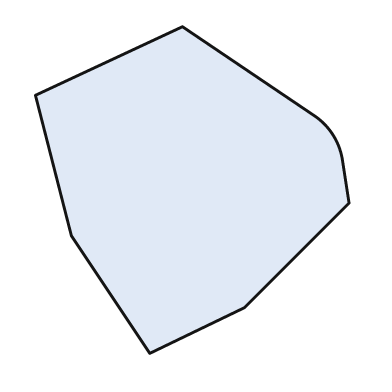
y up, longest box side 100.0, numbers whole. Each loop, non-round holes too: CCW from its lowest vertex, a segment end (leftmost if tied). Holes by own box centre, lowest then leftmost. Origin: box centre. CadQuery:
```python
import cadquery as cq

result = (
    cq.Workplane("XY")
    .moveTo(-13.0, -50.0)
    .lineTo(16.0, -36.0)
    .lineTo(48.0, -4.0)
    .lineTo(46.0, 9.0)
    .threePointArc((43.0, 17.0), (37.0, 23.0))
    .lineTo(-3.0, 50.0)
    .lineTo(-48.0, 29.0)
    .lineTo(-37.0, -14.0)
    .close()
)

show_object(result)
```